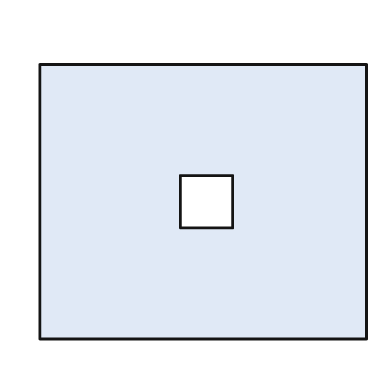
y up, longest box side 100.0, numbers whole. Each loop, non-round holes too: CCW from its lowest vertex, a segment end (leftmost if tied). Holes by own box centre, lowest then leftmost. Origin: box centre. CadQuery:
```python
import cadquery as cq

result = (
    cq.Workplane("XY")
    .moveTo(-50.0, -42.0)
    .lineTo(50.0, -42.0)
    .lineTo(50.0, 42.0)
    .lineTo(-50.0, 42.0)
    .close()
    .moveTo(-7.0, -8.0)
    .lineTo(9.0, -8.0)
    .lineTo(9.0, 8.0)
    .lineTo(-7.0, 8.0)
    .close()
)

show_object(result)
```